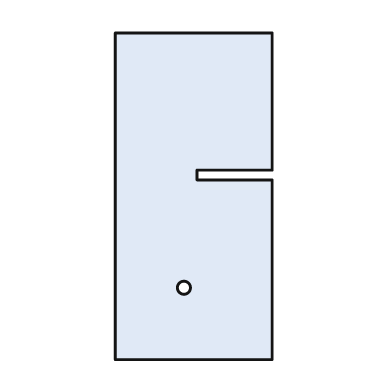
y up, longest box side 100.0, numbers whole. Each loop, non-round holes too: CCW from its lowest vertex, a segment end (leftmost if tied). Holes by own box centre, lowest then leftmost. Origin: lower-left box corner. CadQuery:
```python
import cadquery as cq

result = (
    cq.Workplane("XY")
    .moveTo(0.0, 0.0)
    .lineTo(48.0, 0.0)
    .lineTo(48.0, 55.0)
    .lineTo(25.0, 55.0)
    .lineTo(25.0, 58.0)
    .lineTo(48.0, 58.0)
    .lineTo(48.0, 100.0)
    .lineTo(0.0, 100.0)
    .close()
    .moveTo(21.0, 22.0)
    .circle(2.0)
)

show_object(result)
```